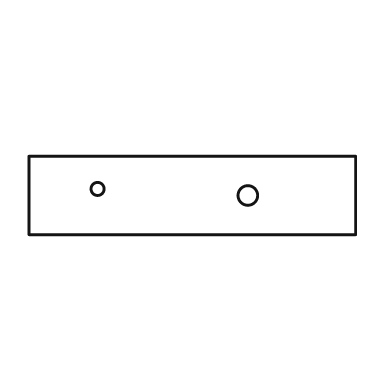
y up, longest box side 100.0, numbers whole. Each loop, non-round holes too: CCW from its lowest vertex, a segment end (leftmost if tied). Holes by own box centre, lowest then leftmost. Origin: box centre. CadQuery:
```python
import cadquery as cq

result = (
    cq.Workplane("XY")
    .moveTo(-50.0, -12.0)
    .lineTo(50.0, -12.0)
    .lineTo(50.0, 12.0)
    .lineTo(-50.0, 12.0)
    .close()
    .moveTo(17.0, 0.0)
    .circle(3.0)
    .moveTo(-29.0, 2.0)
    .circle(2.0)
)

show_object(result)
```